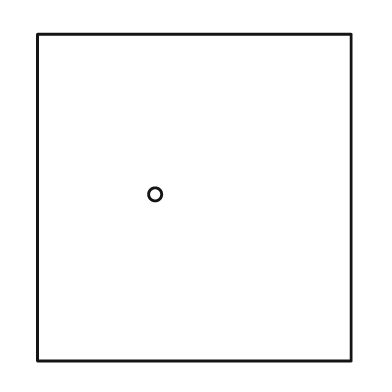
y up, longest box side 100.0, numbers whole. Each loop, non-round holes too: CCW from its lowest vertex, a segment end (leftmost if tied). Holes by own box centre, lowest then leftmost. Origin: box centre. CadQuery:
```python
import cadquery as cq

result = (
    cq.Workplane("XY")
    .moveTo(-48.0, -50.0)
    .lineTo(48.0, -50.0)
    .lineTo(48.0, 50.0)
    .lineTo(-48.0, 50.0)
    .close()
    .moveTo(-12.0, 1.0)
    .circle(2.0)
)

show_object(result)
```